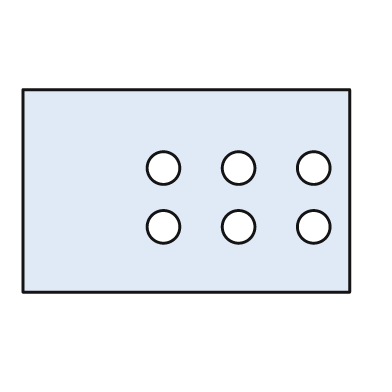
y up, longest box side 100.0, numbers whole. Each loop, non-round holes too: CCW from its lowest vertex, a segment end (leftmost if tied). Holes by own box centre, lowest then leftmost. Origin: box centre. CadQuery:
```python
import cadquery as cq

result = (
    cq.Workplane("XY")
    .moveTo(-50.0, -31.0)
    .lineTo(50.0, -31.0)
    .lineTo(50.0, 31.0)
    .lineTo(-50.0, 31.0)
    .close()
    .moveTo(-7.0, -11.0)
    .circle(5.0)
    .moveTo(16.0, -11.0)
    .circle(5.0)
    .moveTo(39.0, -11.0)
    .circle(5.0)
    .moveTo(-7.0, 7.0)
    .circle(5.0)
    .moveTo(16.0, 7.0)
    .circle(5.0)
    .moveTo(39.0, 7.0)
    .circle(5.0)
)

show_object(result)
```